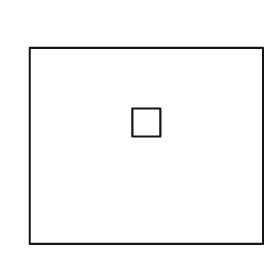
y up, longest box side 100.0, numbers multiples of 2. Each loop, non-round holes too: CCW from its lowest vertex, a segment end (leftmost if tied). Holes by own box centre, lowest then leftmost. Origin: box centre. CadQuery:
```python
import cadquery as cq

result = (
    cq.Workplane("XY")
    .moveTo(-50.0, -42.0)
    .lineTo(50.0, -42.0)
    .lineTo(50.0, 42.0)
    .lineTo(-50.0, 42.0)
    .close()
    .moveTo(-6.0, 4.0)
    .lineTo(6.0, 4.0)
    .lineTo(6.0, 16.0)
    .lineTo(-6.0, 16.0)
    .close()
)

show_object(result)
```